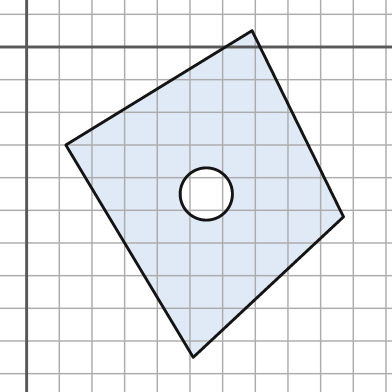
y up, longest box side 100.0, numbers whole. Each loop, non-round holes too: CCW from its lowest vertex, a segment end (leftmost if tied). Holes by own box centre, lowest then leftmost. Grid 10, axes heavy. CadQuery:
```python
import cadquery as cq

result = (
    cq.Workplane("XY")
    .moveTo(51.0, -95.0)
    .lineTo(97.0, -52.0)
    .lineTo(69.0, 5.0)
    .lineTo(12.0, -30.0)
    .close()
    .moveTo(55.0, -45.0)
    .circle(8.0)
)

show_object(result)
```